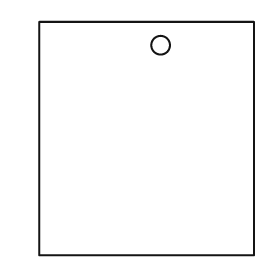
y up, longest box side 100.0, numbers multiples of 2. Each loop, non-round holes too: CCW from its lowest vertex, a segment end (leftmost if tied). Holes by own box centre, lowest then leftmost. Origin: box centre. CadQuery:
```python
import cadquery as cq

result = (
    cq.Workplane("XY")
    .moveTo(-46.0, -50.0)
    .lineTo(46.0, -50.0)
    .lineTo(46.0, 50.0)
    .lineTo(-46.0, 50.0)
    .close()
    .moveTo(6.0, 40.0)
    .circle(4.0)
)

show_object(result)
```